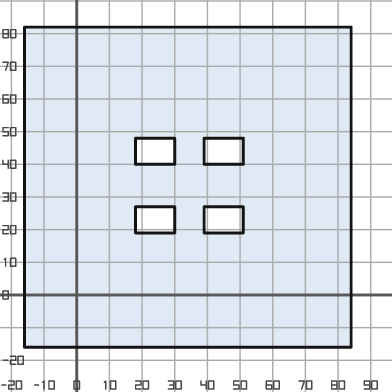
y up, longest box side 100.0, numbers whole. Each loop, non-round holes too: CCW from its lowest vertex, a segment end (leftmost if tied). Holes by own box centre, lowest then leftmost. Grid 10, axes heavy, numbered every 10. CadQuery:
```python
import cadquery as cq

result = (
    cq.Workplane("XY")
    .moveTo(-16.0, -16.0)
    .lineTo(84.0, -16.0)
    .lineTo(84.0, 82.0)
    .lineTo(-16.0, 82.0)
    .close()
    .moveTo(18.0, 19.0)
    .lineTo(30.0, 19.0)
    .lineTo(30.0, 27.0)
    .lineTo(18.0, 27.0)
    .close()
    .moveTo(39.0, 19.0)
    .lineTo(51.0, 19.0)
    .lineTo(51.0, 27.0)
    .lineTo(39.0, 27.0)
    .close()
    .moveTo(18.0, 40.0)
    .lineTo(30.0, 40.0)
    .lineTo(30.0, 48.0)
    .lineTo(18.0, 48.0)
    .close()
    .moveTo(39.0, 40.0)
    .lineTo(51.0, 40.0)
    .lineTo(51.0, 48.0)
    .lineTo(39.0, 48.0)
    .close()
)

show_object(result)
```